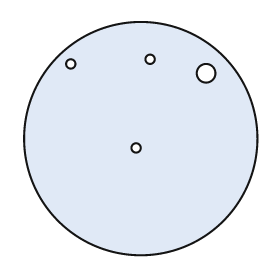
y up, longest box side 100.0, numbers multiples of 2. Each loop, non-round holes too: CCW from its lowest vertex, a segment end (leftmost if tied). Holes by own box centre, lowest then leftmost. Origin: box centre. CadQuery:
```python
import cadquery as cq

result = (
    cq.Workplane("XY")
    .moveTo(0.0, 0.0)
    .circle(50.0)
    .moveTo(-2.0, -4.0)
    .circle(2.0)
    .moveTo(28.0, 28.0)
    .circle(4.0)
    .moveTo(-30.0, 32.0)
    .circle(2.0)
    .moveTo(4.0, 34.0)
    .circle(2.0)
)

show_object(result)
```